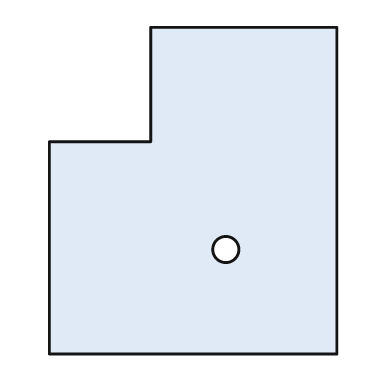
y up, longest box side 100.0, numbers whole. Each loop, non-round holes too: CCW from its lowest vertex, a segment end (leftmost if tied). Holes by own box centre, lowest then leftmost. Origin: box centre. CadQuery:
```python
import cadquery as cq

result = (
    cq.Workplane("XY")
    .moveTo(-44.0, -50.0)
    .lineTo(44.0, -50.0)
    .lineTo(44.0, 50.0)
    .lineTo(-13.0, 50.0)
    .lineTo(-13.0, 15.0)
    .lineTo(-44.0, 15.0)
    .close()
    .moveTo(10.0, -18.0)
    .circle(4.0)
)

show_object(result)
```